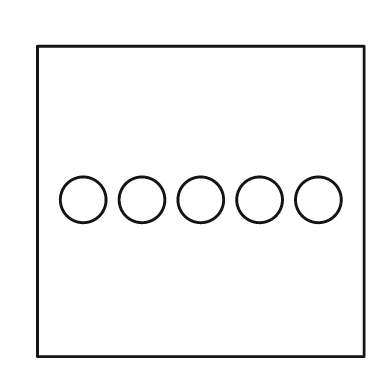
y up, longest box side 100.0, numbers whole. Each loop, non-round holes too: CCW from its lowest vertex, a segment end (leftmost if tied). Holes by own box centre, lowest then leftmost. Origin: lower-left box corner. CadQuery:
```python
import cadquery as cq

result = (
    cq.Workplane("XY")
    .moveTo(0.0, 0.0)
    .lineTo(100.0, 0.0)
    .lineTo(100.0, 95.0)
    .lineTo(0.0, 95.0)
    .close()
    .moveTo(14.0, 48.0)
    .circle(7.0)
    .moveTo(32.0, 48.0)
    .circle(7.0)
    .moveTo(50.0, 48.0)
    .circle(7.0)
    .moveTo(68.0, 48.0)
    .circle(7.0)
    .moveTo(86.0, 48.0)
    .circle(7.0)
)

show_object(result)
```